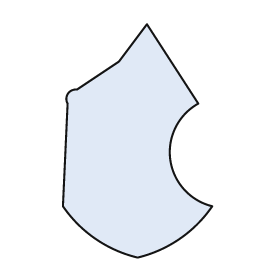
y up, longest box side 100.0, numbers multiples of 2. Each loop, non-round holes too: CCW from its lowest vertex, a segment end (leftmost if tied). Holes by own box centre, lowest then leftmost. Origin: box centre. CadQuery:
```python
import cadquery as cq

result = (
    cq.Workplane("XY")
    .moveTo(0.0, -50.0)
    .threePointArc((18.0, -42.0), (32.0, -28.0))
    .threePointArc((14.0, -8.0), (26.0, 16.0))
    .lineTo(4.0, 50.0)
    .lineTo(-8.0, 34.0)
    .lineTo(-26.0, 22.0)
    .threePointArc((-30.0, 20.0), (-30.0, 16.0))
    .lineTo(-32.0, -28.0)
    .threePointArc((-18.0, -42.0), (0.0, -50.0))
    .close()
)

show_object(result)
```